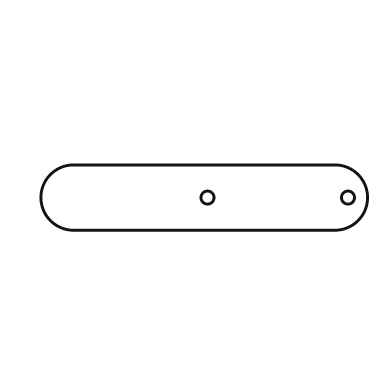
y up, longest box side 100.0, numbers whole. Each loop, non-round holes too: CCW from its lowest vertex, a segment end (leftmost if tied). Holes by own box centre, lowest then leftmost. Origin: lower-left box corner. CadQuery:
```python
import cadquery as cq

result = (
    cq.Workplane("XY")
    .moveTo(10.0, 0.0)
    .lineTo(90.0, 0.0)
    .threePointArc((100.0, 10.0), (90.0, 20.0))
    .lineTo(10.0, 20.0)
    .threePointArc((0.0, 10.0), (10.0, 0.0))
    .close()
    .moveTo(51.0, 10.0)
    .circle(2.0)
    .moveTo(94.0, 10.0)
    .circle(2.0)
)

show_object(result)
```